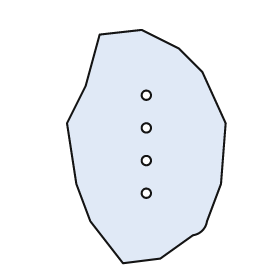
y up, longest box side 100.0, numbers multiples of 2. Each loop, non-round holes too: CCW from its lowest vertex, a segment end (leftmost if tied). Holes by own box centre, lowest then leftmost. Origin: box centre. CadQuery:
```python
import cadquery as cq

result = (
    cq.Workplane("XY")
    .moveTo(-10.0, -50.0)
    .lineTo(6.0, -48.0)
    .lineTo(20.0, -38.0)
    .threePointArc((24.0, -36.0), (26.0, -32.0))
    .lineTo(32.0, -16.0)
    .lineTo(34.0, 10.0)
    .lineTo(24.0, 32.0)
    .lineTo(14.0, 42.0)
    .lineTo(-2.0, 50.0)
    .lineTo(-20.0, 48.0)
    .lineTo(-26.0, 26.0)
    .lineTo(-34.0, 10.0)
    .lineTo(-30.0, -16.0)
    .lineTo(-24.0, -32.0)
    .close()
    .moveTo(0.0, -20.0)
    .circle(2.0)
    .moveTo(0.0, -6.0)
    .circle(2.0)
    .moveTo(0.0, 8.0)
    .circle(2.0)
    .moveTo(0.0, 22.0)
    .circle(2.0)
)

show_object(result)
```